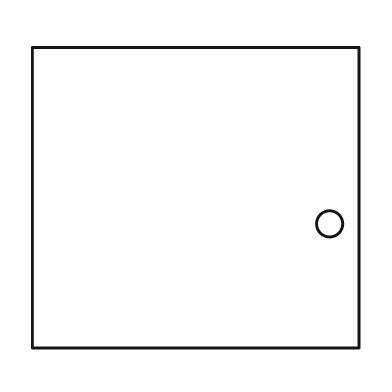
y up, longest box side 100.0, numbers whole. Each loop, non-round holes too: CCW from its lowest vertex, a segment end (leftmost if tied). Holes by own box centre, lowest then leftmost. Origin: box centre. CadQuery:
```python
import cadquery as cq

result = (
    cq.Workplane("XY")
    .moveTo(-50.0, -46.0)
    .lineTo(50.0, -46.0)
    .lineTo(50.0, 46.0)
    .lineTo(-50.0, 46.0)
    .close()
    .moveTo(41.0, -8.0)
    .circle(4.0)
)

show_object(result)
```